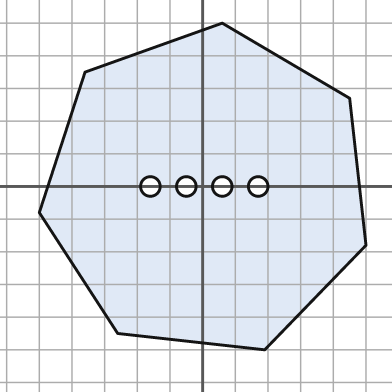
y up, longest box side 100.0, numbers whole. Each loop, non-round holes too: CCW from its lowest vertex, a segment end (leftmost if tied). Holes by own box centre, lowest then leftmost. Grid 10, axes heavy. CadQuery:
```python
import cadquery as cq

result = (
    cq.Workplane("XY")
    .moveTo(19.0, -50.0)
    .lineTo(50.0, -18.0)
    .lineTo(45.0, 27.0)
    .lineTo(6.0, 50.0)
    .lineTo(-36.0, 35.0)
    .lineTo(-50.0, -8.0)
    .lineTo(-26.0, -45.0)
    .close()
    .moveTo(-16.0, 0.0)
    .circle(3.0)
    .moveTo(-5.0, 0.0)
    .circle(3.0)
    .moveTo(6.0, 0.0)
    .circle(3.0)
    .moveTo(17.0, 0.0)
    .circle(3.0)
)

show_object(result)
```